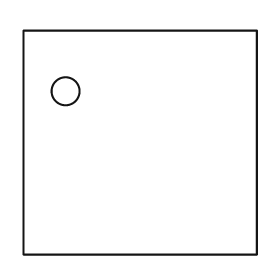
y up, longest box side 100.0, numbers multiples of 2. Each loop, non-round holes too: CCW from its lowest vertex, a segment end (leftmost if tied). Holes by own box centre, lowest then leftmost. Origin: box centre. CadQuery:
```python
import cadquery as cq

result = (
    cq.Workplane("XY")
    .moveTo(-50.0, -48.0)
    .lineTo(50.0, -48.0)
    .lineTo(50.0, 48.0)
    .lineTo(-50.0, 48.0)
    .close()
    .moveTo(-32.0, 22.0)
    .circle(6.0)
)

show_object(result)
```